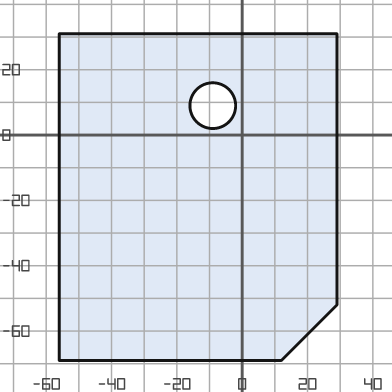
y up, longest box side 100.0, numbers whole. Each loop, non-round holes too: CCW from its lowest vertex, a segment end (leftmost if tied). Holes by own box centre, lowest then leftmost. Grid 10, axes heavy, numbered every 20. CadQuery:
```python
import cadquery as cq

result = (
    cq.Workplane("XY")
    .moveTo(-56.0, -69.0)
    .lineTo(12.0, -69.0)
    .lineTo(29.0, -52.0)
    .lineTo(29.0, 31.0)
    .lineTo(-56.0, 31.0)
    .close()
    .moveTo(-9.0, 9.0)
    .circle(7.0)
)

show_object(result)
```